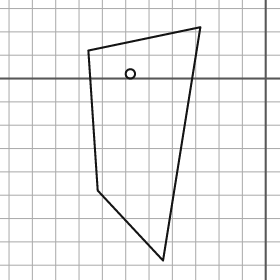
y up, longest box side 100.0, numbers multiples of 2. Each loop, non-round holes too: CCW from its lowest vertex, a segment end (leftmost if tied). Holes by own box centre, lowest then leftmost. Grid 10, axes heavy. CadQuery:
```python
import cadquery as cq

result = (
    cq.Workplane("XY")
    .moveTo(-44.0, -78.0)
    .lineTo(-28.0, 22.0)
    .lineTo(-76.0, 12.0)
    .lineTo(-72.0, -48.0)
    .close()
    .moveTo(-58.0, 2.0)
    .circle(2.0)
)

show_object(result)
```